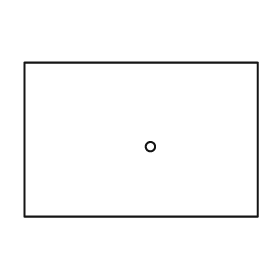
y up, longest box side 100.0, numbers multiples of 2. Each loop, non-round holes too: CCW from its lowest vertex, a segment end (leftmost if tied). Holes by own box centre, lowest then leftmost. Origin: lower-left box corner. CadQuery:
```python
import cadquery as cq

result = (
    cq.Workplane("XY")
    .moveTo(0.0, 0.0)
    .lineTo(100.0, 0.0)
    .lineTo(100.0, 66.0)
    .lineTo(0.0, 66.0)
    .close()
    .moveTo(54.0, 30.0)
    .circle(2.0)
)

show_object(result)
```